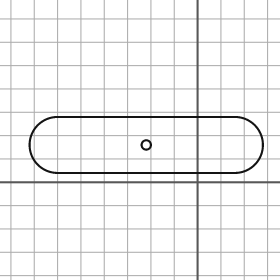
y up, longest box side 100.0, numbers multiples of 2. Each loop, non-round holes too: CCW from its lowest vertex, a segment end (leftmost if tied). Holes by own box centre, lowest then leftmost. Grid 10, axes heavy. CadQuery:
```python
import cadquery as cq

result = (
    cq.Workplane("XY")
    .moveTo(-60.0, 4.0)
    .lineTo(16.0, 4.0)
    .threePointArc((28.0, 16.0), (16.0, 28.0))
    .lineTo(-60.0, 28.0)
    .threePointArc((-72.0, 16.0), (-60.0, 4.0))
    .close()
    .moveTo(-22.0, 16.0)
    .circle(2.0)
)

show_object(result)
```